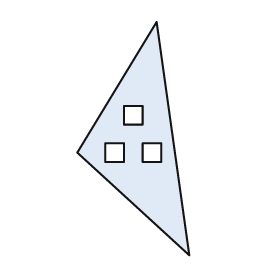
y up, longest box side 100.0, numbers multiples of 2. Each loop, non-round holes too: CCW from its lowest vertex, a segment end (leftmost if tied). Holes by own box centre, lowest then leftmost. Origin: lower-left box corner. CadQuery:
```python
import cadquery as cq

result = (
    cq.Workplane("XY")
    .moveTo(48.0, 0.0)
    .lineTo(34.0, 100.0)
    .lineTo(0.0, 44.0)
    .close()
    .moveTo(12.0, 40.0)
    .lineTo(20.0, 40.0)
    .lineTo(20.0, 48.0)
    .lineTo(12.0, 48.0)
    .close()
    .moveTo(28.0, 40.0)
    .lineTo(36.0, 40.0)
    .lineTo(36.0, 48.0)
    .lineTo(28.0, 48.0)
    .close()
    .moveTo(20.0, 56.0)
    .lineTo(28.0, 56.0)
    .lineTo(28.0, 64.0)
    .lineTo(20.0, 64.0)
    .close()
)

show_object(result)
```